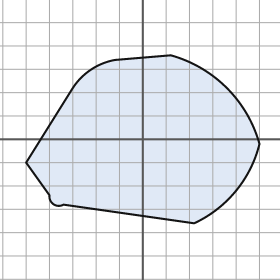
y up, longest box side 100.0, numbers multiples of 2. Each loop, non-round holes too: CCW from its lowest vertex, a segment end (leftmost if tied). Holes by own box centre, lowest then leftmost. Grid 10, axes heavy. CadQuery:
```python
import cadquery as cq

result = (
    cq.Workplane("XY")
    .moveTo(22.0, -36.0)
    .threePointArc((40.0, -22.0), (50.0, -2.0))
    .threePointArc((36.0, 22.0), (12.0, 36.0))
    .lineTo(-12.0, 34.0)
    .threePointArc((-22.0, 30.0), (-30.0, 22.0))
    .lineTo(-50.0, -10.0)
    .lineTo(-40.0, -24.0)
    .threePointArc((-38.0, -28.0), (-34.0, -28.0))
    .close()
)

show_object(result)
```